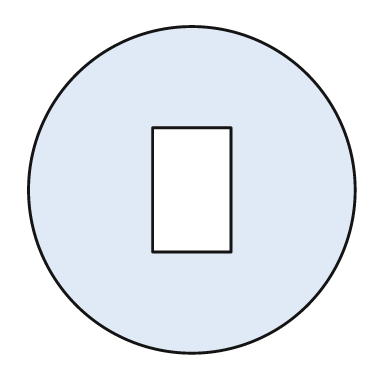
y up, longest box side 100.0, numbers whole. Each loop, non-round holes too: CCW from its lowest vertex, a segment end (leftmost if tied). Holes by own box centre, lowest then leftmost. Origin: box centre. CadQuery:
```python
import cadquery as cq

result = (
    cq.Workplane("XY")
    .moveTo(0.0, 0.0)
    .circle(50.0)
    .moveTo(-12.0, -19.0)
    .lineTo(12.0, -19.0)
    .lineTo(12.0, 19.0)
    .lineTo(-12.0, 19.0)
    .close()
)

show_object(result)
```